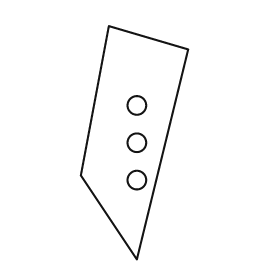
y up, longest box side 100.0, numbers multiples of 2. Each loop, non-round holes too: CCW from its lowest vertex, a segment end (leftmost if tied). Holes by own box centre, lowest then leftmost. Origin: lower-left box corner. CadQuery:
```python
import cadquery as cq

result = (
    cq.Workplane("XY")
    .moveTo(24.0, 0.0)
    .lineTo(46.0, 90.0)
    .lineTo(12.0, 100.0)
    .lineTo(0.0, 36.0)
    .close()
    .moveTo(24.0, 34.0)
    .circle(4.0)
    .moveTo(24.0, 50.0)
    .circle(4.0)
    .moveTo(24.0, 66.0)
    .circle(4.0)
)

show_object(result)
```